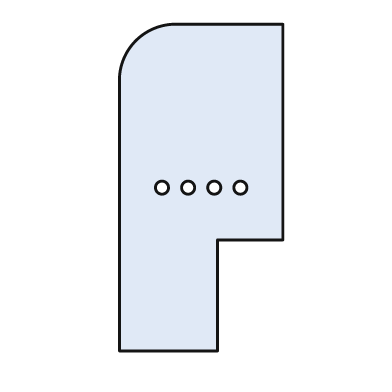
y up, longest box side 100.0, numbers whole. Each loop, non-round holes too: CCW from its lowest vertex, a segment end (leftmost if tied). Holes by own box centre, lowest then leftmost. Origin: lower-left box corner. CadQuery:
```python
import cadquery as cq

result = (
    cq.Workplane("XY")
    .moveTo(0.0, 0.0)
    .lineTo(30.0, 0.0)
    .lineTo(30.0, 34.0)
    .lineTo(50.0, 34.0)
    .lineTo(50.0, 100.0)
    .lineTo(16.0, 100.0)
    .threePointArc((5.0, 95.0), (0.0, 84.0))
    .close()
    .moveTo(13.0, 50.0)
    .circle(2.0)
    .moveTo(21.0, 50.0)
    .circle(2.0)
    .moveTo(29.0, 50.0)
    .circle(2.0)
    .moveTo(37.0, 50.0)
    .circle(2.0)
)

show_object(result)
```